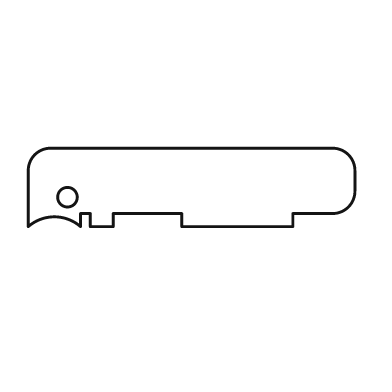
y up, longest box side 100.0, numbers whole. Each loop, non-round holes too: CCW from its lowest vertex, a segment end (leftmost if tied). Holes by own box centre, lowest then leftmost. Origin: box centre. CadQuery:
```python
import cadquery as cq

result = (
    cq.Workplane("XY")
    .moveTo(-50.0, -12.0)
    .threePointArc((-42.0, -9.0), (-34.0, -12.0))
    .lineTo(-34.0, -8.0)
    .lineTo(-31.0, -8.0)
    .lineTo(-31.0, -12.0)
    .lineTo(-24.0, -12.0)
    .lineTo(-24.0, -8.0)
    .lineTo(-3.0, -8.0)
    .lineTo(-3.0, -12.0)
    .lineTo(31.0, -12.0)
    .lineTo(31.0, -8.0)
    .lineTo(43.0, -8.0)
    .threePointArc((48.0, -6.0), (50.0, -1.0))
    .lineTo(50.0, 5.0)
    .threePointArc((48.0, 10.0), (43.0, 12.0))
    .lineTo(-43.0, 12.0)
    .threePointArc((-48.0, 10.0), (-50.0, 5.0))
    .close()
    .moveTo(-38.0, -3.0)
    .circle(3.0)
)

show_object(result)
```